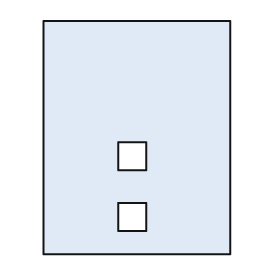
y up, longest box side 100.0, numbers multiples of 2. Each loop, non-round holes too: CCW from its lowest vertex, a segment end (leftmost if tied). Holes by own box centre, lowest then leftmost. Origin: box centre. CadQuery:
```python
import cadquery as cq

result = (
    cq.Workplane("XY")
    .moveTo(-40.0, -50.0)
    .lineTo(40.0, -50.0)
    .lineTo(40.0, 50.0)
    .lineTo(-40.0, 50.0)
    .close()
    .moveTo(-8.0, -40.0)
    .lineTo(4.0, -40.0)
    .lineTo(4.0, -28.0)
    .lineTo(-8.0, -28.0)
    .close()
    .moveTo(-8.0, -14.0)
    .lineTo(4.0, -14.0)
    .lineTo(4.0, -2.0)
    .lineTo(-8.0, -2.0)
    .close()
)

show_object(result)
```